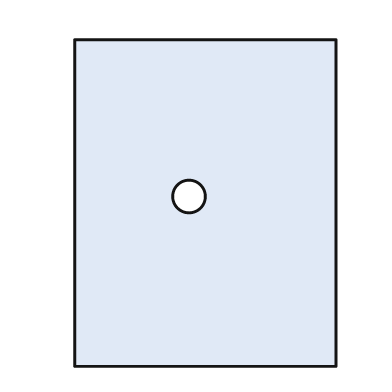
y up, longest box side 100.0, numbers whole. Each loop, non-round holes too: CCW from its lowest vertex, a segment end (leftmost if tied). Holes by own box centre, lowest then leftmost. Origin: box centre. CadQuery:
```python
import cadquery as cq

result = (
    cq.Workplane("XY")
    .moveTo(-40.0, -50.0)
    .lineTo(40.0, -50.0)
    .lineTo(40.0, 50.0)
    .lineTo(-40.0, 50.0)
    .close()
    .moveTo(-5.0, 2.0)
    .circle(5.0)
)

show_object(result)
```